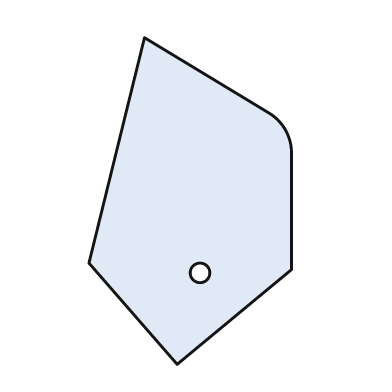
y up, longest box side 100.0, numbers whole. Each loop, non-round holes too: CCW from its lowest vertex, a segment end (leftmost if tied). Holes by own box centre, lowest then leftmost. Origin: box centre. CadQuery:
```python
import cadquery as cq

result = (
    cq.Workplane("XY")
    .moveTo(-4.0, -50.0)
    .lineTo(31.0, -21.0)
    .lineTo(31.0, 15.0)
    .threePointArc((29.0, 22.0), (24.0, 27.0))
    .lineTo(-14.0, 50.0)
    .lineTo(-31.0, -19.0)
    .close()
    .moveTo(3.0, -22.0)
    .circle(3.0)
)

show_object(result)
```